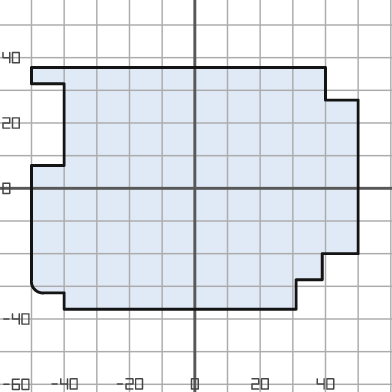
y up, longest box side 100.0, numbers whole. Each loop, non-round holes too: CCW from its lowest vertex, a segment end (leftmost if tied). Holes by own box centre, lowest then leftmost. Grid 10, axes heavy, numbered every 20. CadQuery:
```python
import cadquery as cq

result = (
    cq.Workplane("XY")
    .moveTo(-40.0, -37.0)
    .lineTo(31.0, -37.0)
    .lineTo(31.0, -28.0)
    .lineTo(39.0, -28.0)
    .lineTo(39.0, -20.0)
    .lineTo(50.0, -20.0)
    .lineTo(50.0, 27.0)
    .lineTo(40.0, 27.0)
    .lineTo(40.0, 37.0)
    .lineTo(-50.0, 37.0)
    .lineTo(-50.0, 32.0)
    .lineTo(-40.0, 32.0)
    .lineTo(-40.0, 7.0)
    .lineTo(-50.0, 7.0)
    .lineTo(-50.0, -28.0)
    .threePointArc((-49.0, -31.0), (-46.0, -32.0))
    .lineTo(-40.0, -32.0)
    .close()
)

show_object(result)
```